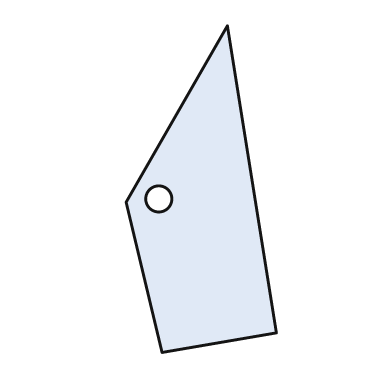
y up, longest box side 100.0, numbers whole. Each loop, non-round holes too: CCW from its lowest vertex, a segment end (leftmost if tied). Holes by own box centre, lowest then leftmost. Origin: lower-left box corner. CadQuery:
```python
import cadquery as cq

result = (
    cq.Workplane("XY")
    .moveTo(11.0, 0.0)
    .lineTo(46.0, 6.0)
    .lineTo(31.0, 100.0)
    .lineTo(0.0, 46.0)
    .close()
    .moveTo(10.0, 47.0)
    .circle(4.0)
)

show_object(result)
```